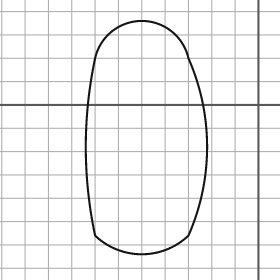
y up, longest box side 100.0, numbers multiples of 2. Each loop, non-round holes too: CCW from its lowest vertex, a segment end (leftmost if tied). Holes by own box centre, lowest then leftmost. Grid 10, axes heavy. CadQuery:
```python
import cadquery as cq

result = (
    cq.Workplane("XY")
    .moveTo(-70.0, -56.0)
    .threePointArc((-50.0, -64.0), (-30.0, -56.0))
    .threePointArc((-22.0, -18.0), (-30.0, 20.0))
    .threePointArc((-50.0, 36.0), (-70.0, 20.0))
    .threePointArc((-74.0, -18.0), (-70.0, -56.0))
    .close()
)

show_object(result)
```